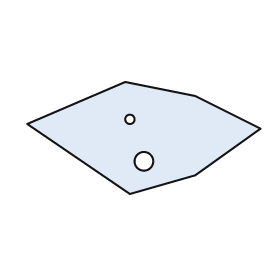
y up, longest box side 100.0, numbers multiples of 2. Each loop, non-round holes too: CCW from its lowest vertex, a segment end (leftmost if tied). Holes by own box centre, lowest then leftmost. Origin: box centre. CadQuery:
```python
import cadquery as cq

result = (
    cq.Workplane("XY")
    .moveTo(-6.0, -24.0)
    .lineTo(22.0, -16.0)
    .lineTo(50.0, 4.0)
    .lineTo(22.0, 18.0)
    .lineTo(-8.0, 24.0)
    .lineTo(-50.0, 6.0)
    .close()
    .moveTo(0.0, -10.0)
    .circle(4.0)
    .moveTo(-6.0, 8.0)
    .circle(2.0)
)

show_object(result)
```